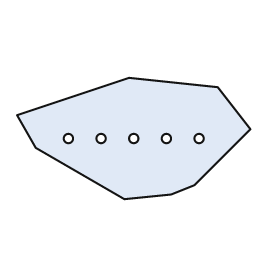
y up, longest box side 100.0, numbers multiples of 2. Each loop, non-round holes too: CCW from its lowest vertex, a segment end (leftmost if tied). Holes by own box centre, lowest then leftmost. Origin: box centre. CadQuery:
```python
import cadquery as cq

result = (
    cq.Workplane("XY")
    .moveTo(-4.0, -26.0)
    .lineTo(16.0, -24.0)
    .lineTo(26.0, -20.0)
    .lineTo(50.0, 4.0)
    .lineTo(36.0, 22.0)
    .lineTo(-2.0, 26.0)
    .lineTo(-50.0, 10.0)
    .lineTo(-42.0, -4.0)
    .close()
    .moveTo(-28.0, 0.0)
    .circle(2.0)
    .moveTo(-14.0, 0.0)
    .circle(2.0)
    .moveTo(0.0, 0.0)
    .circle(2.0)
    .moveTo(14.0, 0.0)
    .circle(2.0)
    .moveTo(28.0, 0.0)
    .circle(2.0)
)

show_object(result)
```